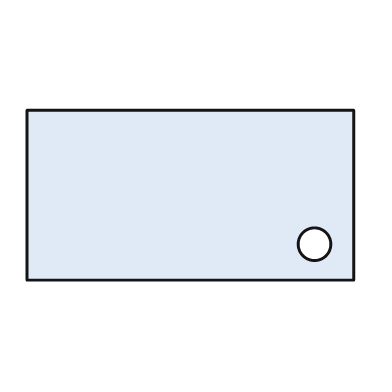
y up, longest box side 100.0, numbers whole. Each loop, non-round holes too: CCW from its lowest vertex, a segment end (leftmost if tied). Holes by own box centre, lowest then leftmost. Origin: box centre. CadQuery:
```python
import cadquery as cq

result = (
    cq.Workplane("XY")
    .moveTo(-50.0, -26.0)
    .lineTo(50.0, -26.0)
    .lineTo(50.0, 26.0)
    .lineTo(-50.0, 26.0)
    .close()
    .moveTo(38.0, -15.0)
    .circle(5.0)
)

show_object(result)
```